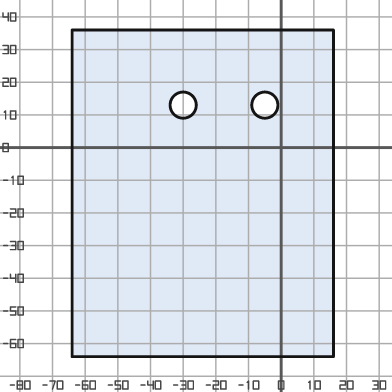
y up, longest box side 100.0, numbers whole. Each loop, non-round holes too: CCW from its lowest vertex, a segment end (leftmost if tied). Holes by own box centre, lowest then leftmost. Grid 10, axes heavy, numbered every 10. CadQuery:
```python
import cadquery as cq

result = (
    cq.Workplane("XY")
    .moveTo(-64.0, -64.0)
    .lineTo(16.0, -64.0)
    .lineTo(16.0, 36.0)
    .lineTo(-64.0, 36.0)
    .close()
    .moveTo(-30.0, 13.0)
    .circle(4.0)
    .moveTo(-5.0, 13.0)
    .circle(4.0)
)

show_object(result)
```